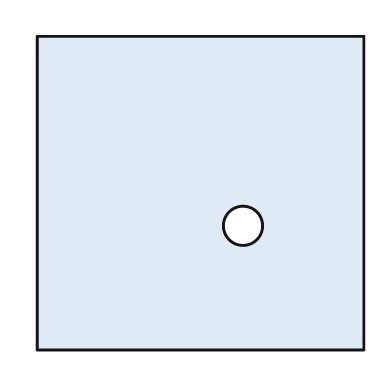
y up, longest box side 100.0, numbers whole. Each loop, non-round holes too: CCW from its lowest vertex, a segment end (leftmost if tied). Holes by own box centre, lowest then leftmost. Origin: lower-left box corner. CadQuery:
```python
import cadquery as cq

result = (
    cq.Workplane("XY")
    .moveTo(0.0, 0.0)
    .lineTo(100.0, 0.0)
    .lineTo(100.0, 96.0)
    .lineTo(0.0, 96.0)
    .close()
    .moveTo(63.0, 38.0)
    .circle(6.0)
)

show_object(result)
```